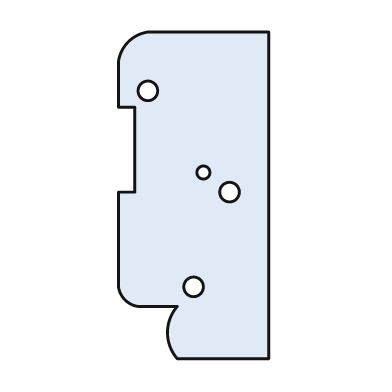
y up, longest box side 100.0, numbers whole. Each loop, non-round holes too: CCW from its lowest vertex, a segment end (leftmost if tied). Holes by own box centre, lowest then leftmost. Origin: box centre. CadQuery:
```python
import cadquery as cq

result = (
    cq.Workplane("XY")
    .moveTo(-5.0, -50.0)
    .lineTo(23.0, -50.0)
    .lineTo(23.0, 50.0)
    .lineTo(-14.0, 50.0)
    .threePointArc((-20.0, 47.0), (-23.0, 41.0))
    .lineTo(-23.0, 27.0)
    .lineTo(-18.0, 27.0)
    .lineTo(-18.0, 1.0)
    .lineTo(-23.0, 1.0)
    .lineTo(-23.0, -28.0)
    .threePointArc((-21.0, -32.0), (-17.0, -34.0))
    .lineTo(-5.0, -34.0)
    .threePointArc((-8.0, -42.0), (-5.0, -50.0))
    .close()
    .moveTo(0.0, -28.0)
    .circle(3.0)
    .moveTo(11.0, 1.0)
    .circle(3.0)
    .moveTo(3.0, 7.0)
    .circle(2.0)
    .moveTo(-14.0, 32.0)
    .circle(3.0)
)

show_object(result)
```